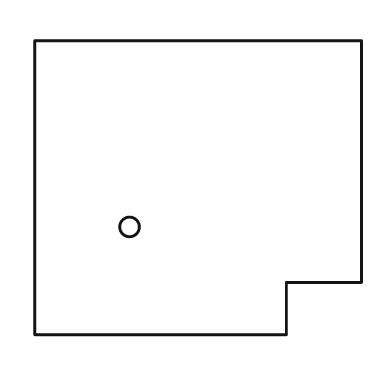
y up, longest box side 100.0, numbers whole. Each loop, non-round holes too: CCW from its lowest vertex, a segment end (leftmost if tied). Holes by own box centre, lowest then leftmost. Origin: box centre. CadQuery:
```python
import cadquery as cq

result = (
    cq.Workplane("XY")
    .moveTo(-50.0, -45.0)
    .lineTo(27.0, -45.0)
    .lineTo(27.0, -29.0)
    .lineTo(50.0, -29.0)
    .lineTo(50.0, 45.0)
    .lineTo(-50.0, 45.0)
    .close()
    .moveTo(-21.0, -12.0)
    .circle(3.0)
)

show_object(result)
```